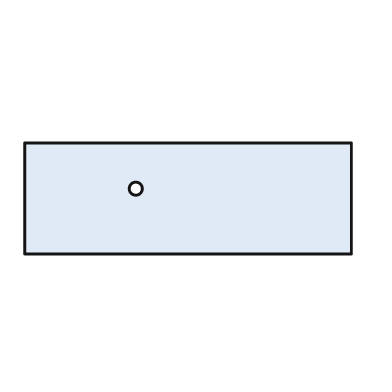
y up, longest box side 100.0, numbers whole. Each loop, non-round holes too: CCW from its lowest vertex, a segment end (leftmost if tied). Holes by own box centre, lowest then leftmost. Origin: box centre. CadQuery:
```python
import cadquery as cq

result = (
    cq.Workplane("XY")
    .moveTo(-50.0, -17.0)
    .lineTo(50.0, -17.0)
    .lineTo(50.0, 17.0)
    .lineTo(-50.0, 17.0)
    .close()
    .moveTo(-16.0, 3.0)
    .circle(2.0)
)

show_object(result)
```